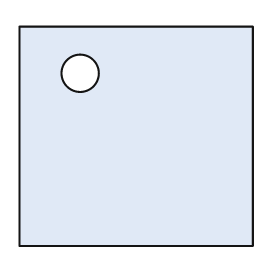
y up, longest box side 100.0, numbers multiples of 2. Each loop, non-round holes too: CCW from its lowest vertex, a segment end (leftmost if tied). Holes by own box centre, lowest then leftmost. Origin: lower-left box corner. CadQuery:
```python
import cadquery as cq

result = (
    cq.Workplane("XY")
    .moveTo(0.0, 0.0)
    .lineTo(100.0, 0.0)
    .lineTo(100.0, 94.0)
    .lineTo(0.0, 94.0)
    .close()
    .moveTo(26.0, 74.0)
    .circle(8.0)
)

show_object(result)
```